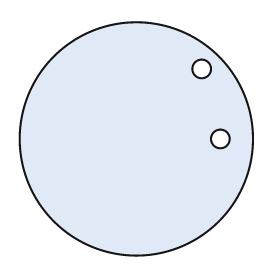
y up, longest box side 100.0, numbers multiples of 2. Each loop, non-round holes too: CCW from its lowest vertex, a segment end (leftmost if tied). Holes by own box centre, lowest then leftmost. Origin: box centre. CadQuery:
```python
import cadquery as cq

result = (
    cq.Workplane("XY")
    .moveTo(0.0, 0.0)
    .circle(50.0)
    .moveTo(36.0, 0.0)
    .circle(4.0)
    .moveTo(28.0, 30.0)
    .circle(4.0)
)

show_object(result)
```